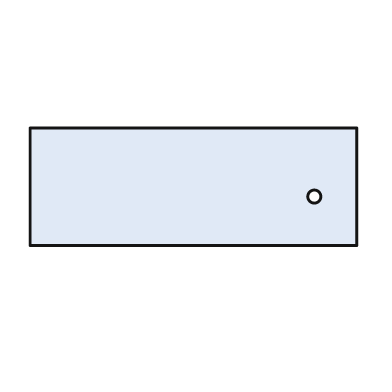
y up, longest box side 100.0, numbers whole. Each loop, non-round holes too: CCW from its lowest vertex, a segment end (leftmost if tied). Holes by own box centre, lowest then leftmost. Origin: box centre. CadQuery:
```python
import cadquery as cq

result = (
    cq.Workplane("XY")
    .moveTo(-50.0, -18.0)
    .lineTo(50.0, -18.0)
    .lineTo(50.0, 18.0)
    .lineTo(-50.0, 18.0)
    .close()
    .moveTo(37.0, -3.0)
    .circle(2.0)
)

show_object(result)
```